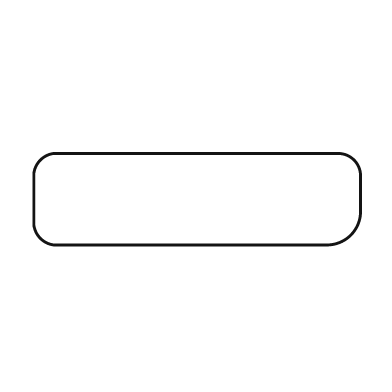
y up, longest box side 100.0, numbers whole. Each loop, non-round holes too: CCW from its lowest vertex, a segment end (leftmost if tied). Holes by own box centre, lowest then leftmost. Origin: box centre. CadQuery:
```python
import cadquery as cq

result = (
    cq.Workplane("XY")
    .moveTo(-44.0, -14.0)
    .lineTo(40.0, -14.0)
    .threePointArc((47.0, -11.0), (50.0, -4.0))
    .lineTo(50.0, 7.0)
    .threePointArc((48.0, 12.0), (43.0, 14.0))
    .lineTo(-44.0, 14.0)
    .threePointArc((-48.0, 12.0), (-50.0, 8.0))
    .lineTo(-50.0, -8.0)
    .threePointArc((-48.0, -12.0), (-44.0, -14.0))
    .close()
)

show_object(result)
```